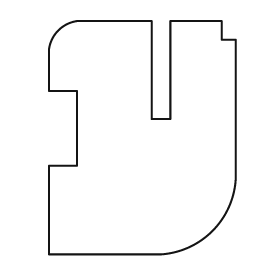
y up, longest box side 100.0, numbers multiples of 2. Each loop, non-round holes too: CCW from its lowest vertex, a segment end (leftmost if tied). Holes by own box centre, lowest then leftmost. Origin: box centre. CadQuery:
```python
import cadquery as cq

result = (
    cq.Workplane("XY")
    .moveTo(-40.0, -50.0)
    .lineTo(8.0, -50.0)
    .threePointArc((30.0, -40.0), (40.0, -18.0))
    .lineTo(40.0, 42.0)
    .lineTo(34.0, 42.0)
    .lineTo(34.0, 50.0)
    .lineTo(12.0, 50.0)
    .lineTo(12.0, 8.0)
    .lineTo(4.0, 8.0)
    .lineTo(4.0, 50.0)
    .lineTo(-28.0, 50.0)
    .threePointArc((-36.0, 46.0), (-40.0, 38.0))
    .lineTo(-40.0, 20.0)
    .lineTo(-28.0, 20.0)
    .lineTo(-28.0, -12.0)
    .lineTo(-40.0, -12.0)
    .close()
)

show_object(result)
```